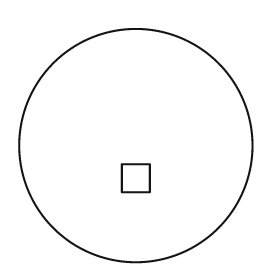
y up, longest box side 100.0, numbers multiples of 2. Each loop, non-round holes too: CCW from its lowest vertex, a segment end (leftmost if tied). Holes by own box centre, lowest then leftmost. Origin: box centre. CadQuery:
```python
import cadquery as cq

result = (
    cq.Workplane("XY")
    .moveTo(0.0, 0.0)
    .circle(50.0)
    .moveTo(-6.0, -20.0)
    .lineTo(6.0, -20.0)
    .lineTo(6.0, -8.0)
    .lineTo(-6.0, -8.0)
    .close()
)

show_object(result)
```